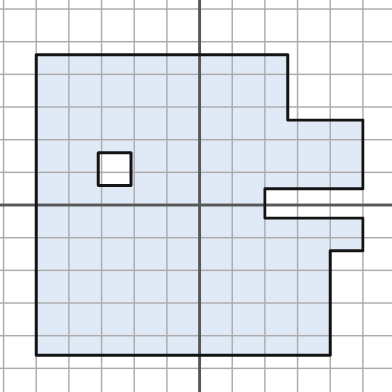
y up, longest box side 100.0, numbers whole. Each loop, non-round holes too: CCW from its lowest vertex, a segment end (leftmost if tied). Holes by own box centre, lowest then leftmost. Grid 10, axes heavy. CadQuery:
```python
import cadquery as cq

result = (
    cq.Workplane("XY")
    .moveTo(-50.0, -46.0)
    .lineTo(40.0, -46.0)
    .lineTo(40.0, -14.0)
    .lineTo(50.0, -14.0)
    .lineTo(50.0, -4.0)
    .lineTo(20.0, -4.0)
    .lineTo(20.0, 5.0)
    .lineTo(50.0, 5.0)
    .lineTo(50.0, 26.0)
    .lineTo(27.0, 26.0)
    .lineTo(27.0, 46.0)
    .lineTo(-50.0, 46.0)
    .close()
    .moveTo(-31.0, 6.0)
    .lineTo(-21.0, 6.0)
    .lineTo(-21.0, 16.0)
    .lineTo(-31.0, 16.0)
    .close()
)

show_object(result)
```